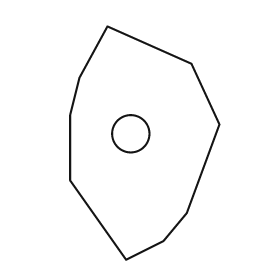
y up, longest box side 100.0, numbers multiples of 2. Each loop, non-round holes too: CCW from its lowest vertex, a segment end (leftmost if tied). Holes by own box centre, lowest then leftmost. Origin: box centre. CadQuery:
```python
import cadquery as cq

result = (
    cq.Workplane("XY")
    .moveTo(-8.0, -50.0)
    .lineTo(8.0, -42.0)
    .lineTo(18.0, -30.0)
    .lineTo(32.0, 8.0)
    .lineTo(20.0, 34.0)
    .lineTo(-16.0, 50.0)
    .lineTo(-28.0, 28.0)
    .lineTo(-32.0, 12.0)
    .lineTo(-32.0, -16.0)
    .close()
    .moveTo(-6.0, 4.0)
    .circle(8.0)
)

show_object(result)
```